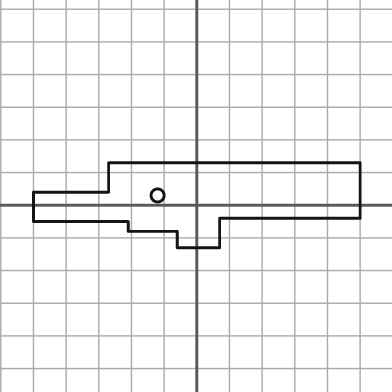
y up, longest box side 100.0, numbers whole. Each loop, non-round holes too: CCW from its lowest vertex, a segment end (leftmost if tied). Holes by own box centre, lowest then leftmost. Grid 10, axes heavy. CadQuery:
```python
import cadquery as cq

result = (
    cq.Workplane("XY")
    .moveTo(-6.0, -13.0)
    .lineTo(7.0, -13.0)
    .lineTo(7.0, -4.0)
    .lineTo(50.0, -4.0)
    .lineTo(50.0, 13.0)
    .lineTo(-27.0, 13.0)
    .lineTo(-27.0, 4.0)
    .lineTo(-50.0, 4.0)
    .lineTo(-50.0, -5.0)
    .lineTo(-21.0, -5.0)
    .lineTo(-21.0, -8.0)
    .lineTo(-6.0, -8.0)
    .close()
    .moveTo(-12.0, 3.0)
    .circle(2.0)
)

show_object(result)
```